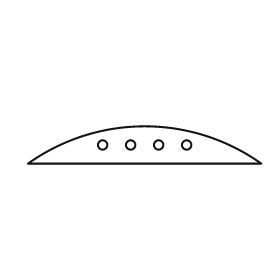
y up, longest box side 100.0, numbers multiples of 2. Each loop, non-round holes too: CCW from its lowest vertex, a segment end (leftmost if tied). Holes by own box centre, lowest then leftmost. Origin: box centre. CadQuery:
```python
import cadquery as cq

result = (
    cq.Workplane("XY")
    .moveTo(-50.0, -8.0)
    .lineTo(50.0, -8.0)
    .threePointArc((0.0, 8.0), (-50.0, -8.0))
    .close()
    .moveTo(-18.0, 0.0)
    .circle(2.0)
    .moveTo(-6.0, 0.0)
    .circle(2.0)
    .moveTo(6.0, 0.0)
    .circle(2.0)
    .moveTo(18.0, 0.0)
    .circle(2.0)
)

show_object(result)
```